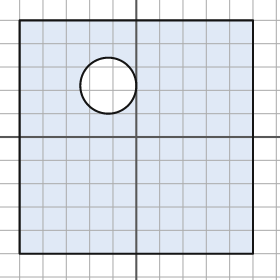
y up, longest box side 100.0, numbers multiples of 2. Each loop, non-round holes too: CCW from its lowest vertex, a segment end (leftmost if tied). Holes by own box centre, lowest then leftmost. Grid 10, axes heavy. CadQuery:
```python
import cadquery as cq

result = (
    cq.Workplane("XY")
    .moveTo(-50.0, -50.0)
    .lineTo(50.0, -50.0)
    .lineTo(50.0, 50.0)
    .lineTo(-50.0, 50.0)
    .close()
    .moveTo(-12.0, 22.0)
    .circle(12.0)
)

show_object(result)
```